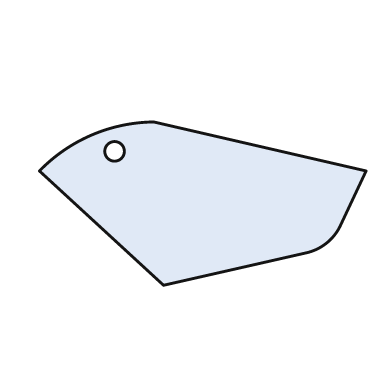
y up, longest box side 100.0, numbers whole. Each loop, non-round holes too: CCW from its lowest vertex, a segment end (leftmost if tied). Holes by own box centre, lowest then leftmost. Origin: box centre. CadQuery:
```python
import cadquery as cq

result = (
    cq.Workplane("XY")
    .moveTo(-12.0, -25.0)
    .lineTo(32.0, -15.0)
    .threePointArc((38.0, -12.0), (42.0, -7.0))
    .lineTo(50.0, 10.0)
    .lineTo(-15.0, 25.0)
    .threePointArc((-34.0, 21.0), (-50.0, 10.0))
    .close()
    .moveTo(-27.0, 16.0)
    .circle(3.0)
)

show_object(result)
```